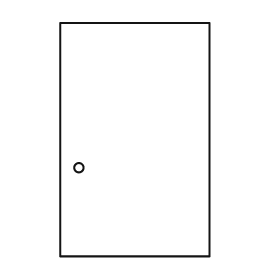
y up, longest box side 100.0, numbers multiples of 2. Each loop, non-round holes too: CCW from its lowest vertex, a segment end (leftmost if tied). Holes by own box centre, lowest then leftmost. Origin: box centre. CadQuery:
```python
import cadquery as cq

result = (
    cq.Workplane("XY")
    .moveTo(-32.0, -50.0)
    .lineTo(32.0, -50.0)
    .lineTo(32.0, 50.0)
    .lineTo(-32.0, 50.0)
    .close()
    .moveTo(-24.0, -12.0)
    .circle(2.0)
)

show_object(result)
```